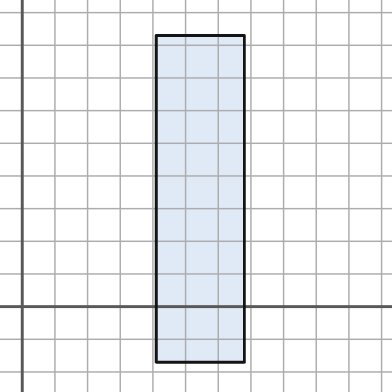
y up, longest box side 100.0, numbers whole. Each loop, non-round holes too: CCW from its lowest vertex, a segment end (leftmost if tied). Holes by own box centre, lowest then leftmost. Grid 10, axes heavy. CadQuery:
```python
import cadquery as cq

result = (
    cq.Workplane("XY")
    .moveTo(41.0, -17.0)
    .lineTo(68.0, -17.0)
    .lineTo(68.0, 83.0)
    .lineTo(41.0, 83.0)
    .close()
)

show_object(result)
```